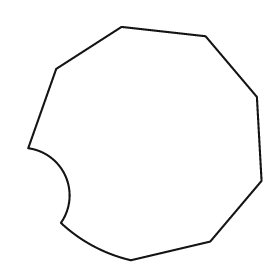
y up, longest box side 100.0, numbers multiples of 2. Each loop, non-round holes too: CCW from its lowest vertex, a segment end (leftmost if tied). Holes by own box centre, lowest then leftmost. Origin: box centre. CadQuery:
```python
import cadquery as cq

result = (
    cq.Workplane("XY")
    .moveTo(-6.0, -50.0)
    .lineTo(28.0, -42.0)
    .lineTo(50.0, -16.0)
    .lineTo(48.0, 20.0)
    .lineTo(26.0, 46.0)
    .lineTo(-10.0, 50.0)
    .lineTo(-38.0, 32.0)
    .lineTo(-50.0, -2.0)
    .threePointArc((-34.0, -14.0), (-36.0, -34.0))
    .threePointArc((-22.0, -44.0), (-6.0, -50.0))
    .close()
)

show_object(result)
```